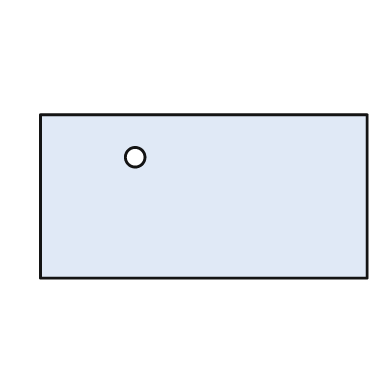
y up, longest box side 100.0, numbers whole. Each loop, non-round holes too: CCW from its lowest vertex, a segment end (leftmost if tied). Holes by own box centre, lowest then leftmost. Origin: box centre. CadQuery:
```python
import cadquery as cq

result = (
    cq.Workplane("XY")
    .moveTo(-50.0, -25.0)
    .lineTo(50.0, -25.0)
    .lineTo(50.0, 25.0)
    .lineTo(-50.0, 25.0)
    .close()
    .moveTo(-21.0, 12.0)
    .circle(3.0)
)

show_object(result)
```